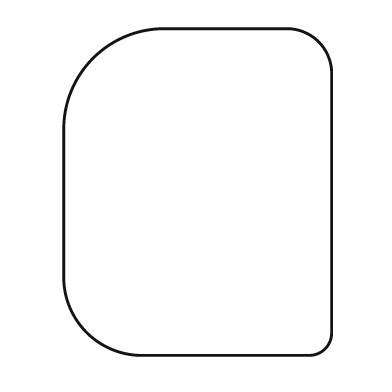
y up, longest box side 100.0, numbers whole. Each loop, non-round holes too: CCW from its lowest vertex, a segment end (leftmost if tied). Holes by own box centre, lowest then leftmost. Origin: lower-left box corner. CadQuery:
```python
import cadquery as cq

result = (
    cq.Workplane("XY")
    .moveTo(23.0, 0.0)
    .lineTo(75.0, 0.0)
    .threePointArc((80.0, 2.0), (82.0, 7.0))
    .lineTo(82.0, 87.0)
    .threePointArc((78.0, 96.0), (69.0, 100.0))
    .lineTo(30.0, 100.0)
    .threePointArc((9.0, 91.0), (0.0, 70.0))
    .lineTo(0.0, 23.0)
    .threePointArc((7.0, 7.0), (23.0, 0.0))
    .close()
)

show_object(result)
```